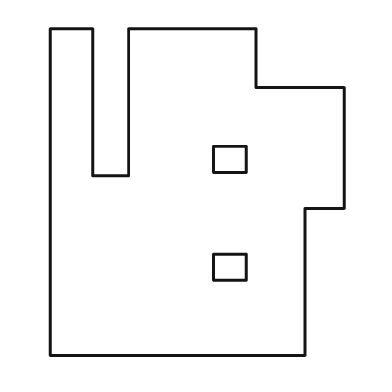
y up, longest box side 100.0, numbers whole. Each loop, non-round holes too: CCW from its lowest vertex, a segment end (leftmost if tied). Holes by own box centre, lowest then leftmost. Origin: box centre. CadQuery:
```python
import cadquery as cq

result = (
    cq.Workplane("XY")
    .moveTo(-45.0, -50.0)
    .lineTo(33.0, -50.0)
    .lineTo(33.0, -5.0)
    .lineTo(45.0, -5.0)
    .lineTo(45.0, 32.0)
    .lineTo(18.0, 32.0)
    .lineTo(18.0, 50.0)
    .lineTo(-21.0, 50.0)
    .lineTo(-21.0, 5.0)
    .lineTo(-32.0, 5.0)
    .lineTo(-32.0, 50.0)
    .lineTo(-45.0, 50.0)
    .close()
    .moveTo(5.0, -27.0)
    .lineTo(15.0, -27.0)
    .lineTo(15.0, -19.0)
    .lineTo(5.0, -19.0)
    .close()
    .moveTo(5.0, 6.0)
    .lineTo(15.0, 6.0)
    .lineTo(15.0, 14.0)
    .lineTo(5.0, 14.0)
    .close()
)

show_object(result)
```